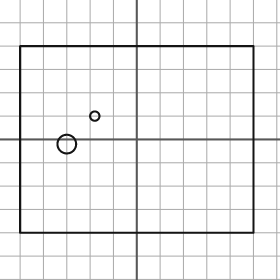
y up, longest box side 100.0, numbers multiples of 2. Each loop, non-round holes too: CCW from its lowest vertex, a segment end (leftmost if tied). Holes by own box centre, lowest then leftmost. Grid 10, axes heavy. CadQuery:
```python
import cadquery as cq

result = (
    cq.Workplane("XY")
    .moveTo(-50.0, -40.0)
    .lineTo(50.0, -40.0)
    .lineTo(50.0, 40.0)
    .lineTo(-50.0, 40.0)
    .close()
    .moveTo(-30.0, -2.0)
    .circle(4.0)
    .moveTo(-18.0, 10.0)
    .circle(2.0)
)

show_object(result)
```